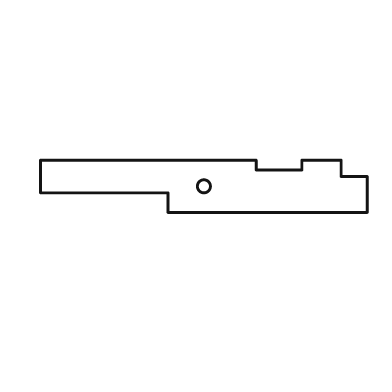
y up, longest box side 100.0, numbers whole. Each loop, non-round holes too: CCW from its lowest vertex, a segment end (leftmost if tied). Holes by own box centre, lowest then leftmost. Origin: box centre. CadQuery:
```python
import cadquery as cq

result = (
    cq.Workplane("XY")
    .moveTo(-11.0, -8.0)
    .lineTo(50.0, -8.0)
    .lineTo(50.0, 3.0)
    .lineTo(42.0, 3.0)
    .lineTo(42.0, 8.0)
    .lineTo(30.0, 8.0)
    .lineTo(30.0, 5.0)
    .lineTo(16.0, 5.0)
    .lineTo(16.0, 8.0)
    .lineTo(-50.0, 8.0)
    .lineTo(-50.0, -2.0)
    .lineTo(-11.0, -2.0)
    .close()
    .moveTo(0.0, 0.0)
    .circle(2.0)
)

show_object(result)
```